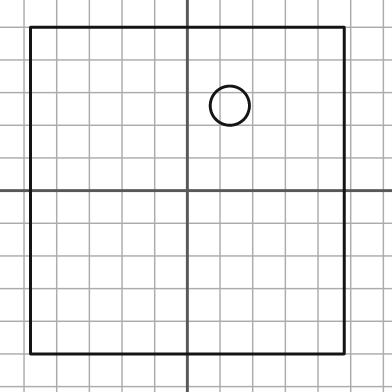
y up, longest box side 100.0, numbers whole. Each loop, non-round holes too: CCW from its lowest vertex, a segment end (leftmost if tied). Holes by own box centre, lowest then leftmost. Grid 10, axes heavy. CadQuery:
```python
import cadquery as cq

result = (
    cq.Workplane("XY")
    .moveTo(-48.0, -50.0)
    .lineTo(48.0, -50.0)
    .lineTo(48.0, 50.0)
    .lineTo(-48.0, 50.0)
    .close()
    .moveTo(13.0, 26.0)
    .circle(6.0)
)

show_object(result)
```